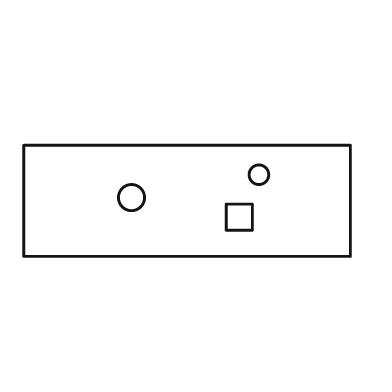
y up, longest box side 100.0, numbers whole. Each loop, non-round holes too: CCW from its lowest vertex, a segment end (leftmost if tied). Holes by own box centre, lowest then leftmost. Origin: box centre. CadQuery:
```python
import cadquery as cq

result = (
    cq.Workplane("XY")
    .moveTo(-50.0, -17.0)
    .lineTo(50.0, -17.0)
    .lineTo(50.0, 17.0)
    .lineTo(-50.0, 17.0)
    .close()
    .moveTo(12.0, -9.0)
    .lineTo(20.0, -9.0)
    .lineTo(20.0, -1.0)
    .lineTo(12.0, -1.0)
    .close()
    .moveTo(-17.0, 1.0)
    .circle(4.0)
    .moveTo(22.0, 8.0)
    .circle(3.0)
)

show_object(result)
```